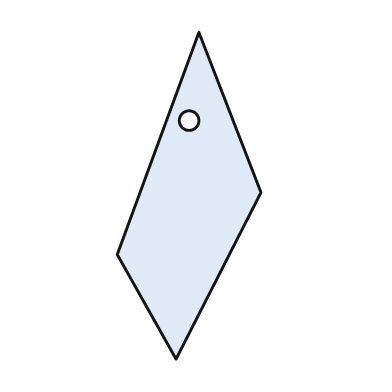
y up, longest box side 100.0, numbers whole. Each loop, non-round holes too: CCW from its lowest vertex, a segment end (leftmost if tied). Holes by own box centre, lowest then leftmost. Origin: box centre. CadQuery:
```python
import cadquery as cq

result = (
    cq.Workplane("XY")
    .moveTo(-4.0, -50.0)
    .lineTo(22.0, 1.0)
    .lineTo(3.0, 50.0)
    .lineTo(-22.0, -18.0)
    .close()
    .moveTo(0.0, 23.0)
    .circle(3.0)
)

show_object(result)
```